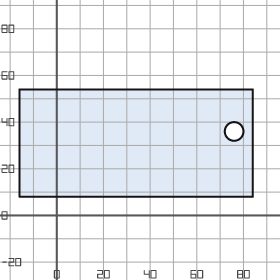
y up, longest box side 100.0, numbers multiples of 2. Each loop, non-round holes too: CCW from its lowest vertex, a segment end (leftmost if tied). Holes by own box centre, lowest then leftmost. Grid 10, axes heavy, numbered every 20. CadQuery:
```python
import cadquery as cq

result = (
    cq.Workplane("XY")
    .moveTo(-16.0, 8.0)
    .lineTo(84.0, 8.0)
    .lineTo(84.0, 54.0)
    .lineTo(-16.0, 54.0)
    .close()
    .moveTo(76.0, 36.0)
    .circle(4.0)
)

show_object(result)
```